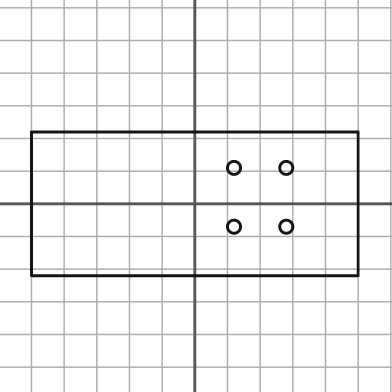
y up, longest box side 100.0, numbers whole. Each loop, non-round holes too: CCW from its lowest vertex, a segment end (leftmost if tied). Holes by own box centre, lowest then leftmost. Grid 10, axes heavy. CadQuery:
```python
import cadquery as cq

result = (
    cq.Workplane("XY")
    .moveTo(-50.0, -22.0)
    .lineTo(50.0, -22.0)
    .lineTo(50.0, 22.0)
    .lineTo(-50.0, 22.0)
    .close()
    .moveTo(12.0, -7.0)
    .circle(2.0)
    .moveTo(28.0, -7.0)
    .circle(2.0)
    .moveTo(12.0, 11.0)
    .circle(2.0)
    .moveTo(28.0, 11.0)
    .circle(2.0)
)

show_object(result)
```